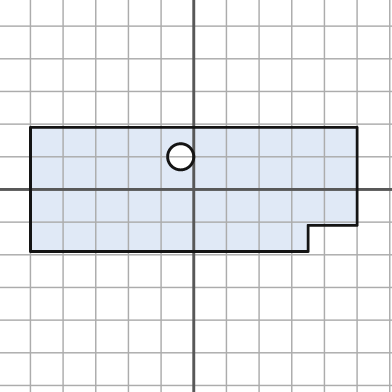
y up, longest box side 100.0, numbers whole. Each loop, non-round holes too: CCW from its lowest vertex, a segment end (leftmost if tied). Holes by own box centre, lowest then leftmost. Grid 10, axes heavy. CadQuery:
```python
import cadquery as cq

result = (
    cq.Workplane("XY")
    .moveTo(-50.0, -19.0)
    .lineTo(35.0, -19.0)
    .lineTo(35.0, -11.0)
    .lineTo(50.0, -11.0)
    .lineTo(50.0, 19.0)
    .lineTo(-50.0, 19.0)
    .close()
    .moveTo(-4.0, 10.0)
    .circle(4.0)
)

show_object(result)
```